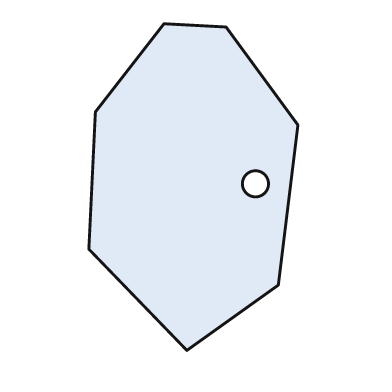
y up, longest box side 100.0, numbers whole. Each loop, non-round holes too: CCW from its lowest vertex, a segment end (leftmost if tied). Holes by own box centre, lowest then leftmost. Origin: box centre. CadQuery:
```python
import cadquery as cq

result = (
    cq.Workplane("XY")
    .moveTo(-2.0, -50.0)
    .lineTo(26.0, -30.0)
    .lineTo(32.0, 19.0)
    .lineTo(10.0, 49.0)
    .lineTo(-9.0, 50.0)
    .lineTo(-30.0, 23.0)
    .lineTo(-32.0, -19.0)
    .close()
    .moveTo(19.0, 1.0)
    .circle(4.0)
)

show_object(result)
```